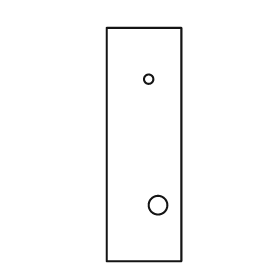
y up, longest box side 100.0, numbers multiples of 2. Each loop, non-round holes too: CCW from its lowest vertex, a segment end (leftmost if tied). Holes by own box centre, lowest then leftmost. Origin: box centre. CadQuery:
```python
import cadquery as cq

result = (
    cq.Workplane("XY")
    .moveTo(-16.0, -50.0)
    .lineTo(16.0, -50.0)
    .lineTo(16.0, 50.0)
    .lineTo(-16.0, 50.0)
    .close()
    .moveTo(6.0, -26.0)
    .circle(4.0)
    .moveTo(2.0, 28.0)
    .circle(2.0)
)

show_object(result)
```